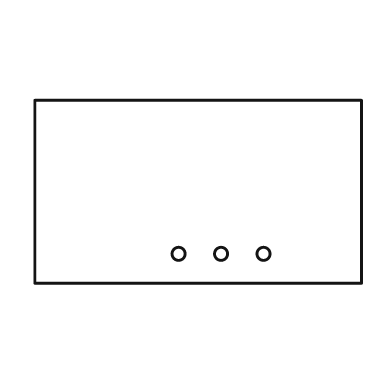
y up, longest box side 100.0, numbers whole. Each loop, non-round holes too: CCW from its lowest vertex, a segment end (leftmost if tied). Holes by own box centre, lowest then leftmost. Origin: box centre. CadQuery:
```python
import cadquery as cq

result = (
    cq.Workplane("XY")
    .moveTo(-50.0, -28.0)
    .lineTo(50.0, -28.0)
    .lineTo(50.0, 28.0)
    .lineTo(-50.0, 28.0)
    .close()
    .moveTo(-6.0, -19.0)
    .circle(2.0)
    .moveTo(7.0, -19.0)
    .circle(2.0)
    .moveTo(20.0, -19.0)
    .circle(2.0)
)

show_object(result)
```